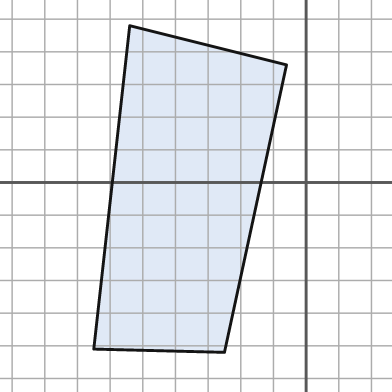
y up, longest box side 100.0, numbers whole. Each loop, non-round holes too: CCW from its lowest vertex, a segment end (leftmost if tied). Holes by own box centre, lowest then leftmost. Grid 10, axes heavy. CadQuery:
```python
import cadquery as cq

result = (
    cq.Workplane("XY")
    .moveTo(-25.0, -52.0)
    .lineTo(-6.0, 36.0)
    .lineTo(-54.0, 48.0)
    .lineTo(-65.0, -51.0)
    .close()
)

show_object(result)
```